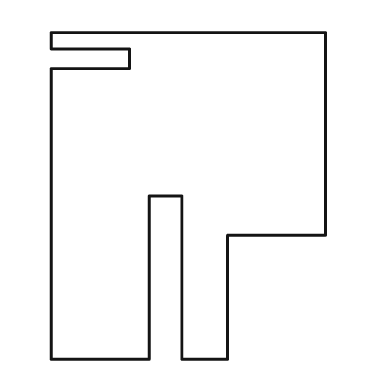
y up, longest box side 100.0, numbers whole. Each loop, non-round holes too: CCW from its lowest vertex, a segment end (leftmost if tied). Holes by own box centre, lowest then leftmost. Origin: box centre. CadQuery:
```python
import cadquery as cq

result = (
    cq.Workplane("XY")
    .moveTo(-42.0, -50.0)
    .lineTo(-12.0, -50.0)
    .lineTo(-12.0, 0.0)
    .lineTo(-2.0, 0.0)
    .lineTo(-2.0, -50.0)
    .lineTo(12.0, -50.0)
    .lineTo(12.0, -12.0)
    .lineTo(42.0, -12.0)
    .lineTo(42.0, 50.0)
    .lineTo(-42.0, 50.0)
    .lineTo(-42.0, 45.0)
    .lineTo(-18.0, 45.0)
    .lineTo(-18.0, 39.0)
    .lineTo(-42.0, 39.0)
    .close()
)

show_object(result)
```